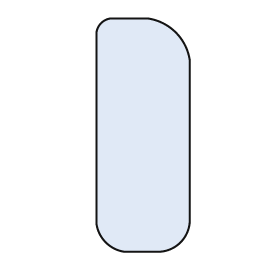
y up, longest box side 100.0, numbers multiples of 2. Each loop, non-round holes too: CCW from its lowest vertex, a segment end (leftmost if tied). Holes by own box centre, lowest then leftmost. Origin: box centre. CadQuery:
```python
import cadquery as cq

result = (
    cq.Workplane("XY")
    .moveTo(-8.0, -50.0)
    .lineTo(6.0, -50.0)
    .threePointArc((16.0, -46.0), (20.0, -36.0))
    .lineTo(20.0, 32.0)
    .threePointArc((14.0, 44.0), (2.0, 50.0))
    .lineTo(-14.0, 50.0)
    .threePointArc((-18.0, 48.0), (-20.0, 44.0))
    .lineTo(-20.0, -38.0)
    .threePointArc((-16.0, -46.0), (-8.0, -50.0))
    .close()
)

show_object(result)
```